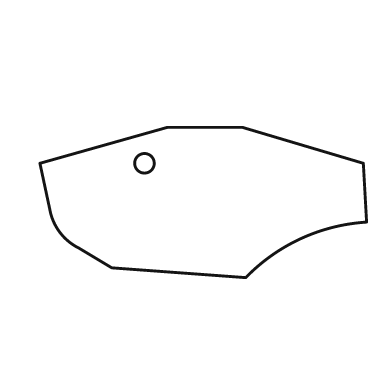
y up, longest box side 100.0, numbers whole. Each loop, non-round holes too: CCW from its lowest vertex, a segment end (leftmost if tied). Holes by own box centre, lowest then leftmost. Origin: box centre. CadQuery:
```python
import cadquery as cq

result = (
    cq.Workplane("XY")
    .moveTo(13.0, -23.0)
    .threePointArc((30.0, -11.0), (50.0, -6.0))
    .lineTo(49.0, 12.0)
    .lineTo(12.0, 23.0)
    .lineTo(-11.0, 23.0)
    .lineTo(-50.0, 12.0)
    .lineTo(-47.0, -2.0)
    .threePointArc((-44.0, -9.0), (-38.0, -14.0))
    .lineTo(-28.0, -20.0)
    .close()
    .moveTo(-18.0, 12.0)
    .circle(3.0)
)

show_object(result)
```